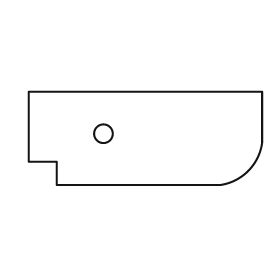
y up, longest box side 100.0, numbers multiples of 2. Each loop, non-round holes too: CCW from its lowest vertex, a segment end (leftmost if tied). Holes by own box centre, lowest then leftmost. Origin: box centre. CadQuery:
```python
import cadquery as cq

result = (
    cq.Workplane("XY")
    .moveTo(-38.0, -20.0)
    .lineTo(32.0, -20.0)
    .threePointArc((44.0, -14.0), (50.0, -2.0))
    .lineTo(50.0, 20.0)
    .lineTo(-50.0, 20.0)
    .lineTo(-50.0, -10.0)
    .lineTo(-38.0, -10.0)
    .close()
    .moveTo(-18.0, 2.0)
    .circle(4.0)
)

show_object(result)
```